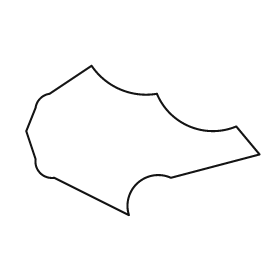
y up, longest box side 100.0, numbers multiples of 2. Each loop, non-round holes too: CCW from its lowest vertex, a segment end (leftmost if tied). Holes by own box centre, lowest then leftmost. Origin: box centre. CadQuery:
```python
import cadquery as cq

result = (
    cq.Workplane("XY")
    .moveTo(-6.0, -32.0)
    .threePointArc((-2.0, -18.0), (12.0, -16.0))
    .lineTo(50.0, -6.0)
    .lineTo(40.0, 6.0)
    .threePointArc((20.0, 6.0), (6.0, 20.0))
    .threePointArc((-10.0, 22.0), (-22.0, 32.0))
    .lineTo(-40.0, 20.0)
    .threePointArc((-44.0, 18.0), (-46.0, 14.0))
    .lineTo(-50.0, 4.0)
    .lineTo(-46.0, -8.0)
    .threePointArc((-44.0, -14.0), (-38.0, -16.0))
    .close()
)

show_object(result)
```